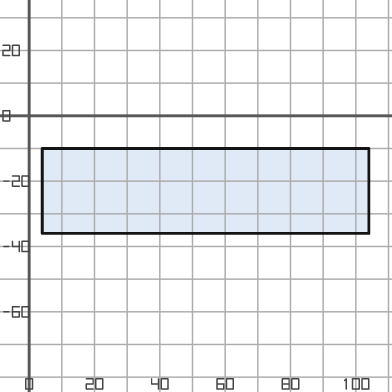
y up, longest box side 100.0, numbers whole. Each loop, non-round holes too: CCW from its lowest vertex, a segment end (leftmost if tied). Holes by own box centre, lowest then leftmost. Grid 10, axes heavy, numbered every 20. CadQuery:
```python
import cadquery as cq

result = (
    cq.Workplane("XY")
    .moveTo(4.0, -36.0)
    .lineTo(104.0, -36.0)
    .lineTo(104.0, -10.0)
    .lineTo(4.0, -10.0)
    .close()
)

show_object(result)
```